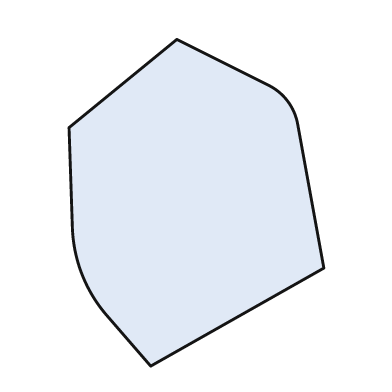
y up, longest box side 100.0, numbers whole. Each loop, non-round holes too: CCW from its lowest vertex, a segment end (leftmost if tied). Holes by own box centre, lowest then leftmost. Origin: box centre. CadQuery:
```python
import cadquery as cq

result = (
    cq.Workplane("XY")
    .moveTo(-14.0, -50.0)
    .lineTo(39.0, -20.0)
    .lineTo(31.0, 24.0)
    .threePointArc((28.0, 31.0), (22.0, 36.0))
    .lineTo(-6.0, 50.0)
    .lineTo(-39.0, 23.0)
    .lineTo(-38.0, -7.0)
    .threePointArc((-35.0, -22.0), (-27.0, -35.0))
    .close()
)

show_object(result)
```